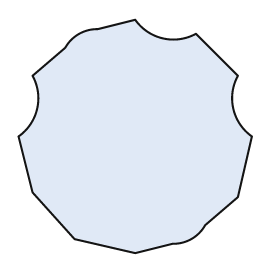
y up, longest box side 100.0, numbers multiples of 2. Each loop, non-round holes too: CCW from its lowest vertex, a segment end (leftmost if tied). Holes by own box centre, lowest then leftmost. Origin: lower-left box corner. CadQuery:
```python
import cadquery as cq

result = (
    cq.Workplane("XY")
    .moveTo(50.0, 0.0)
    .lineTo(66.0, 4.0)
    .threePointArc((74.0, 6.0), (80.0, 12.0))
    .lineTo(94.0, 24.0)
    .lineTo(100.0, 50.0)
    .threePointArc((92.0, 62.0), (94.0, 76.0))
    .lineTo(76.0, 94.0)
    .threePointArc((62.0, 92.0), (50.0, 100.0))
    .lineTo(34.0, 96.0)
    .threePointArc((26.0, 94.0), (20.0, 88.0))
    .lineTo(6.0, 76.0)
    .threePointArc((8.0, 62.0), (0.0, 50.0))
    .lineTo(6.0, 26.0)
    .lineTo(24.0, 6.0)
    .close()
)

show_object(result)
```